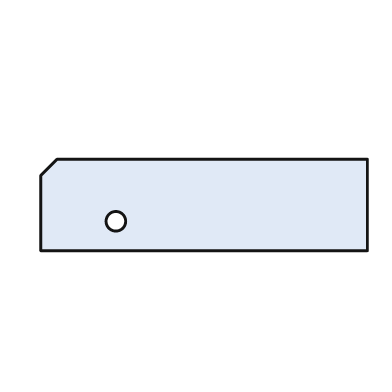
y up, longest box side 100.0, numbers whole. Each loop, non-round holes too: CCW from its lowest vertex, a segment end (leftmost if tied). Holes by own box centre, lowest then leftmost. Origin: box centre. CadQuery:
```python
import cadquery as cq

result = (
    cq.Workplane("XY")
    .moveTo(-50.0, -14.0)
    .lineTo(50.0, -14.0)
    .lineTo(50.0, 14.0)
    .lineTo(-45.0, 14.0)
    .lineTo(-50.0, 9.0)
    .close()
    .moveTo(-27.0, -5.0)
    .circle(3.0)
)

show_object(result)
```